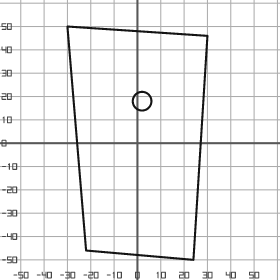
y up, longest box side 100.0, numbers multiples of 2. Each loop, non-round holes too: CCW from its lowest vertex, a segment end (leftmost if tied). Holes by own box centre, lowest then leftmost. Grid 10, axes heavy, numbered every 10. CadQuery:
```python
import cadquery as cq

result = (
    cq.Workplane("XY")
    .moveTo(24.0, -50.0)
    .lineTo(30.0, 46.0)
    .lineTo(-30.0, 50.0)
    .lineTo(-22.0, -46.0)
    .close()
    .moveTo(2.0, 18.0)
    .circle(4.0)
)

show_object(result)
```